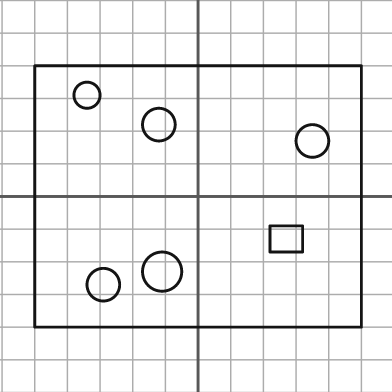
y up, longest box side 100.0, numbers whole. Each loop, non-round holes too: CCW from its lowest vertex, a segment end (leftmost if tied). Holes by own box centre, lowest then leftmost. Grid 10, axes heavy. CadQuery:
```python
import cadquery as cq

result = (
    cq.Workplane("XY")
    .moveTo(-50.0, -40.0)
    .lineTo(50.0, -40.0)
    .lineTo(50.0, 40.0)
    .lineTo(-50.0, 40.0)
    .close()
    .moveTo(-29.0, -27.0)
    .circle(5.0)
    .moveTo(-11.0, -23.0)
    .circle(6.0)
    .moveTo(22.0, -17.0)
    .lineTo(32.0, -17.0)
    .lineTo(32.0, -9.0)
    .lineTo(22.0, -9.0)
    .close()
    .moveTo(35.0, 17.0)
    .circle(5.0)
    .moveTo(-12.0, 22.0)
    .circle(5.0)
    .moveTo(-34.0, 31.0)
    .circle(4.0)
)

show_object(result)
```